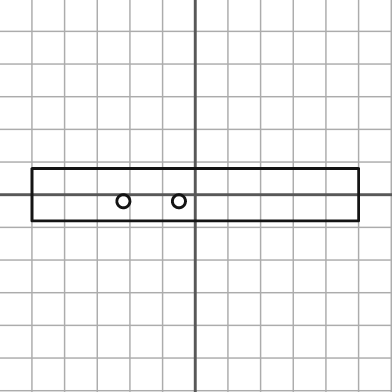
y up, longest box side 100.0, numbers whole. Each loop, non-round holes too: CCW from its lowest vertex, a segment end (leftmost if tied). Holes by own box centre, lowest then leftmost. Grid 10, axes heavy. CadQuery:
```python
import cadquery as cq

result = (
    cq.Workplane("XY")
    .moveTo(-50.0, -8.0)
    .lineTo(50.0, -8.0)
    .lineTo(50.0, 8.0)
    .lineTo(-50.0, 8.0)
    .close()
    .moveTo(-22.0, -2.0)
    .circle(2.0)
    .moveTo(-5.0, -2.0)
    .circle(2.0)
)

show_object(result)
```